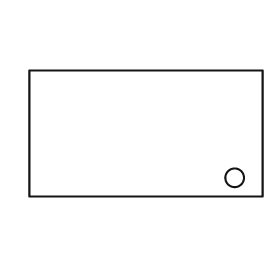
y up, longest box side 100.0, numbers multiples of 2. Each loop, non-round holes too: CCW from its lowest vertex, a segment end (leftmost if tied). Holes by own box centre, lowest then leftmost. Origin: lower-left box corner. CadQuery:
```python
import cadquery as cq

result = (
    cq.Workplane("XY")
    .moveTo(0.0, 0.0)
    .lineTo(100.0, 0.0)
    .lineTo(100.0, 54.0)
    .lineTo(0.0, 54.0)
    .close()
    .moveTo(88.0, 8.0)
    .circle(4.0)
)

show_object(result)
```